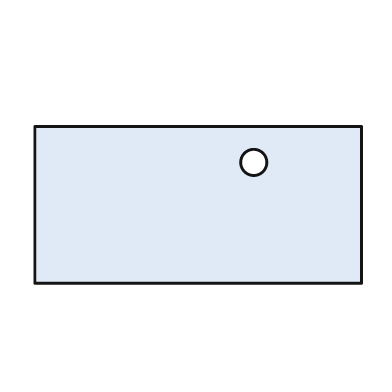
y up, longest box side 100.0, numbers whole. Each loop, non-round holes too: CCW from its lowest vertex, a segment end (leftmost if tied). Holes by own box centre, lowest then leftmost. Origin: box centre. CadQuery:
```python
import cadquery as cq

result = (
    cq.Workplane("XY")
    .moveTo(-50.0, -24.0)
    .lineTo(50.0, -24.0)
    .lineTo(50.0, 24.0)
    .lineTo(-50.0, 24.0)
    .close()
    .moveTo(17.0, 13.0)
    .circle(4.0)
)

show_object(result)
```